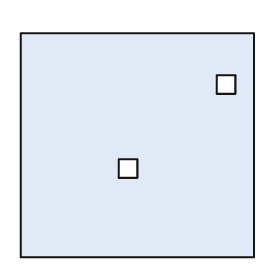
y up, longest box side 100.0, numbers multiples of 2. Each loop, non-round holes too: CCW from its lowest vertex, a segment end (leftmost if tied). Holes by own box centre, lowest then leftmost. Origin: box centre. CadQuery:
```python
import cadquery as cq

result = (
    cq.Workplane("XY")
    .moveTo(-50.0, -48.0)
    .lineTo(50.0, -48.0)
    .lineTo(50.0, 48.0)
    .lineTo(-50.0, 48.0)
    .close()
    .moveTo(-8.0, -14.0)
    .lineTo(0.0, -14.0)
    .lineTo(0.0, -6.0)
    .lineTo(-8.0, -6.0)
    .close()
    .moveTo(34.0, 22.0)
    .lineTo(42.0, 22.0)
    .lineTo(42.0, 30.0)
    .lineTo(34.0, 30.0)
    .close()
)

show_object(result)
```